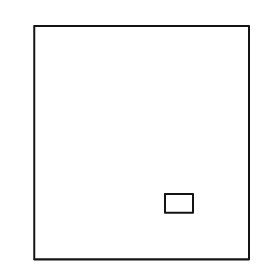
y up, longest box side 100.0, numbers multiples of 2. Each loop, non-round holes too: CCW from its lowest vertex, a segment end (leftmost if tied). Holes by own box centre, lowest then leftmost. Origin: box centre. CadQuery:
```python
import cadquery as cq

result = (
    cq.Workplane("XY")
    .moveTo(-46.0, -50.0)
    .lineTo(46.0, -50.0)
    .lineTo(46.0, 50.0)
    .lineTo(-46.0, 50.0)
    .close()
    .moveTo(10.0, -30.0)
    .lineTo(22.0, -30.0)
    .lineTo(22.0, -22.0)
    .lineTo(10.0, -22.0)
    .close()
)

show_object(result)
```